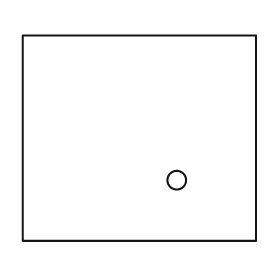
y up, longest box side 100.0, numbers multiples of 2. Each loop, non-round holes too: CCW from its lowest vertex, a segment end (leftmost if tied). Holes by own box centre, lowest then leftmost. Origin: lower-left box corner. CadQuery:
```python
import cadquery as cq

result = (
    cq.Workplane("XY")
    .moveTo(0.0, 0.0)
    .lineTo(100.0, 0.0)
    .lineTo(100.0, 88.0)
    .lineTo(0.0, 88.0)
    .close()
    .moveTo(66.0, 26.0)
    .circle(4.0)
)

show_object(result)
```